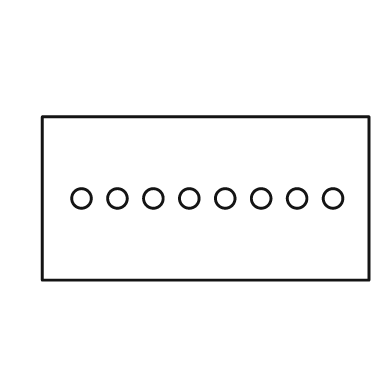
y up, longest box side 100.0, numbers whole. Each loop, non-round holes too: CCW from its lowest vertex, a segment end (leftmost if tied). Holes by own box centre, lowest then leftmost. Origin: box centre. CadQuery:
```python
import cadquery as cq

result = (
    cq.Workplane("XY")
    .moveTo(-50.0, -25.0)
    .lineTo(50.0, -25.0)
    .lineTo(50.0, 25.0)
    .lineTo(-50.0, 25.0)
    .close()
    .moveTo(-38.0, 0.0)
    .circle(3.0)
    .moveTo(-27.0, 0.0)
    .circle(3.0)
    .moveTo(-16.0, 0.0)
    .circle(3.0)
    .moveTo(-5.0, 0.0)
    .circle(3.0)
    .moveTo(6.0, 0.0)
    .circle(3.0)
    .moveTo(17.0, 0.0)
    .circle(3.0)
    .moveTo(28.0, 0.0)
    .circle(3.0)
    .moveTo(39.0, 0.0)
    .circle(3.0)
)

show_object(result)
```